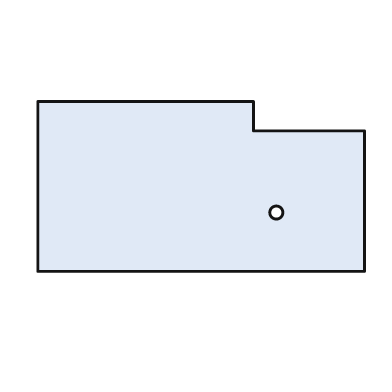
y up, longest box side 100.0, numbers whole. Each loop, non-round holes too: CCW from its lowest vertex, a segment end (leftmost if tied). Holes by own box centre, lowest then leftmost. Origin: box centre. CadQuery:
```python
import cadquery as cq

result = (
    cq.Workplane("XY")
    .moveTo(-50.0, -26.0)
    .lineTo(50.0, -26.0)
    .lineTo(50.0, 17.0)
    .lineTo(16.0, 17.0)
    .lineTo(16.0, 26.0)
    .lineTo(-50.0, 26.0)
    .close()
    .moveTo(23.0, -8.0)
    .circle(2.0)
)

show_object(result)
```